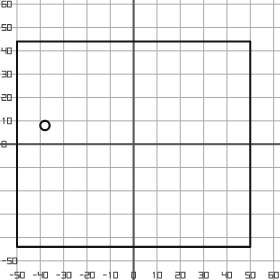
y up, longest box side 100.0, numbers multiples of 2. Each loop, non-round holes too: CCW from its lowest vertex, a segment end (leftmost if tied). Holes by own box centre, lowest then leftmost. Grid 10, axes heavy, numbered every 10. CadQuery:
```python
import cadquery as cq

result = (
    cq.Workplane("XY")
    .moveTo(-50.0, -44.0)
    .lineTo(50.0, -44.0)
    .lineTo(50.0, 44.0)
    .lineTo(-50.0, 44.0)
    .close()
    .moveTo(-38.0, 8.0)
    .circle(2.0)
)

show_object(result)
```